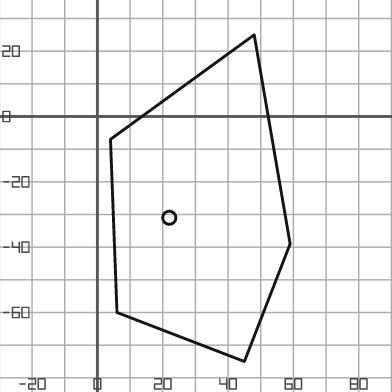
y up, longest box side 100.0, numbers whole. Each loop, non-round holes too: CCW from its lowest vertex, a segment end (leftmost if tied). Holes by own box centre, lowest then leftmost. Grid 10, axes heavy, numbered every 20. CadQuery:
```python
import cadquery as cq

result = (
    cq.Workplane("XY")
    .moveTo(45.0, -75.0)
    .lineTo(59.0, -39.0)
    .lineTo(48.0, 25.0)
    .lineTo(4.0, -7.0)
    .lineTo(6.0, -60.0)
    .close()
    .moveTo(22.0, -31.0)
    .circle(2.0)
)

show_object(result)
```